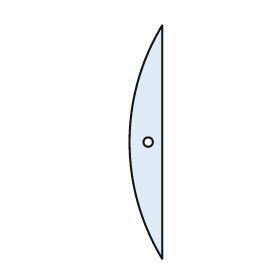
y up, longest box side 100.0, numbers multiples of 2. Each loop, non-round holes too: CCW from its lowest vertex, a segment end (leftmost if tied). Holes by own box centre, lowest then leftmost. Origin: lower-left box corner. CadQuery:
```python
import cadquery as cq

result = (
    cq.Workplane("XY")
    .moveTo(14.0, 0.0)
    .lineTo(14.0, 100.0)
    .threePointArc((0.0, 50.0), (14.0, 0.0))
    .close()
    .moveTo(8.0, 50.0)
    .circle(2.0)
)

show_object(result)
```